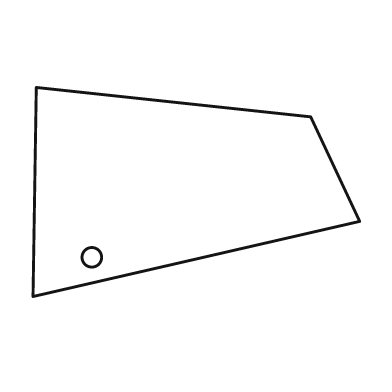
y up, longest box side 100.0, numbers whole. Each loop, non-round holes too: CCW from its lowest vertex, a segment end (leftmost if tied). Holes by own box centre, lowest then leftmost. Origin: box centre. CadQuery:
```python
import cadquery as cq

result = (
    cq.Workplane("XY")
    .moveTo(-50.0, -32.0)
    .lineTo(50.0, -9.0)
    .lineTo(35.0, 23.0)
    .lineTo(-49.0, 32.0)
    .close()
    .moveTo(-32.0, -20.0)
    .circle(3.0)
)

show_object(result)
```